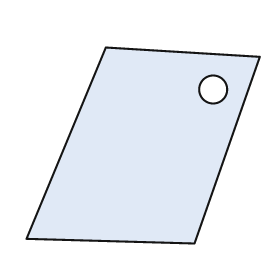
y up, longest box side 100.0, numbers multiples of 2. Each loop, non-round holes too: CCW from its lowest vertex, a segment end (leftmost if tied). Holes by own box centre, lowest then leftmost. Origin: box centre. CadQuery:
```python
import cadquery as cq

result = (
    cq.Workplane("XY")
    .moveTo(22.0, -42.0)
    .lineTo(50.0, 38.0)
    .lineTo(-16.0, 42.0)
    .lineTo(-50.0, -40.0)
    .close()
    .moveTo(30.0, 24.0)
    .circle(6.0)
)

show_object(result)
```